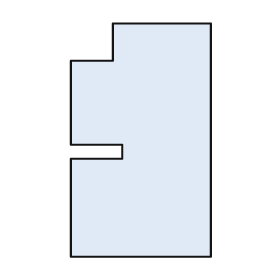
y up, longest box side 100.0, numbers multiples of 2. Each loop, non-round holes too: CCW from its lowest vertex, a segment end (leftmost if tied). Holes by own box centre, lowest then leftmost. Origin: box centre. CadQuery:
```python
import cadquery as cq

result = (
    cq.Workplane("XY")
    .moveTo(-30.0, -50.0)
    .lineTo(30.0, -50.0)
    .lineTo(30.0, 50.0)
    .lineTo(-12.0, 50.0)
    .lineTo(-12.0, 34.0)
    .lineTo(-30.0, 34.0)
    .lineTo(-30.0, -2.0)
    .lineTo(-8.0, -2.0)
    .lineTo(-8.0, -8.0)
    .lineTo(-30.0, -8.0)
    .close()
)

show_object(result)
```